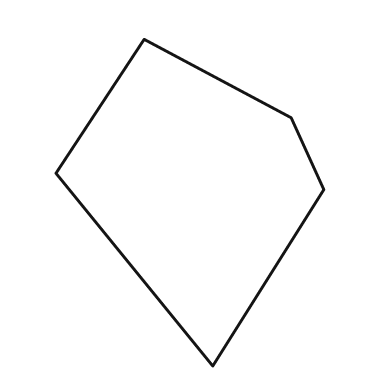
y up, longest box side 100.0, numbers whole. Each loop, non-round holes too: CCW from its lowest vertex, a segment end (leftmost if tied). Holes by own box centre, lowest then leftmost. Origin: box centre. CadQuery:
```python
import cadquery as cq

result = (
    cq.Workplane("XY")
    .moveTo(7.0, -50.0)
    .lineTo(41.0, 4.0)
    .lineTo(31.0, 26.0)
    .lineTo(-14.0, 50.0)
    .lineTo(-41.0, 9.0)
    .close()
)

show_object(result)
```